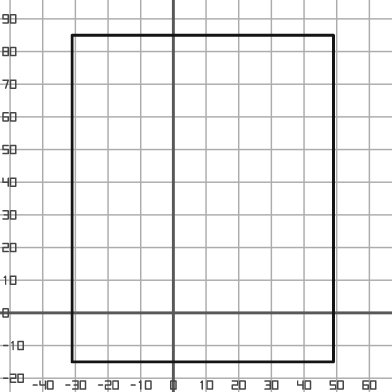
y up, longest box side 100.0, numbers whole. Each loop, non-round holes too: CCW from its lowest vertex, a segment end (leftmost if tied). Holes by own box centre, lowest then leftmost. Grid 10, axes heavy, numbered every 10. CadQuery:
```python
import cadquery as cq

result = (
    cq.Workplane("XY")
    .moveTo(-31.0, -15.0)
    .lineTo(49.0, -15.0)
    .lineTo(49.0, 85.0)
    .lineTo(-31.0, 85.0)
    .close()
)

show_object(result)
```